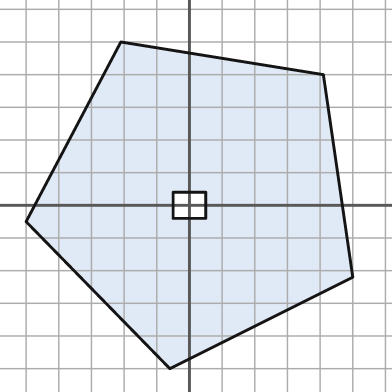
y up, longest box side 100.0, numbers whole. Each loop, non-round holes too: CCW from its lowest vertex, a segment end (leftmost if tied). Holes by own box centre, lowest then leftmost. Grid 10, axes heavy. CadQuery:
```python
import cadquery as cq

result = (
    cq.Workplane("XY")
    .moveTo(-6.0, -50.0)
    .lineTo(50.0, -22.0)
    .lineTo(41.0, 40.0)
    .lineTo(-21.0, 50.0)
    .lineTo(-50.0, -5.0)
    .close()
    .moveTo(-5.0, -4.0)
    .lineTo(5.0, -4.0)
    .lineTo(5.0, 4.0)
    .lineTo(-5.0, 4.0)
    .close()
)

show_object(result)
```